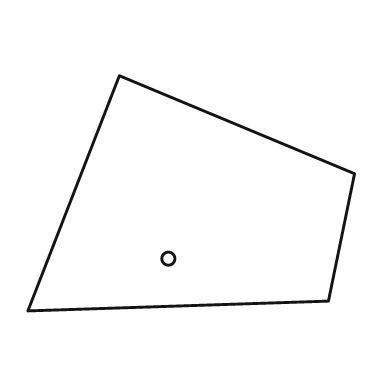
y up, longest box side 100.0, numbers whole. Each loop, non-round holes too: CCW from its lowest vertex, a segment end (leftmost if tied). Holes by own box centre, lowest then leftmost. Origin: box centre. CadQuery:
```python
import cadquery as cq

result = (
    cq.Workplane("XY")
    .moveTo(-50.0, -36.0)
    .lineTo(42.0, -33.0)
    .lineTo(50.0, 6.0)
    .lineTo(-22.0, 36.0)
    .close()
    .moveTo(-7.0, -20.0)
    .circle(2.0)
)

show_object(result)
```